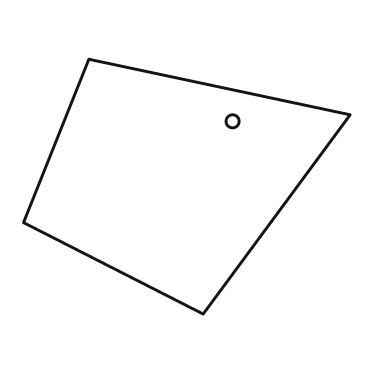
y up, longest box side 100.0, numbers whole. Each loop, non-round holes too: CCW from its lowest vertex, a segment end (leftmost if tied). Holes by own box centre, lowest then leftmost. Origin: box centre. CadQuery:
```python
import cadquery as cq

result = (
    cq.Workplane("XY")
    .moveTo(5.0, -39.0)
    .lineTo(50.0, 22.0)
    .lineTo(-30.0, 39.0)
    .lineTo(-50.0, -11.0)
    .close()
    .moveTo(14.0, 20.0)
    .circle(2.0)
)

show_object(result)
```